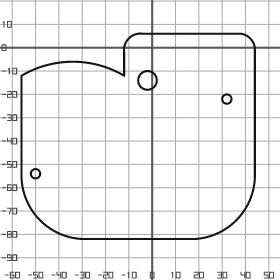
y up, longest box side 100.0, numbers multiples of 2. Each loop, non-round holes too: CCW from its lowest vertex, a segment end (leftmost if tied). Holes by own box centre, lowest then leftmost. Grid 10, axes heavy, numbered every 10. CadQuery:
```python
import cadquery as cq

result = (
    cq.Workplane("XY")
    .moveTo(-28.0, -82.0)
    .lineTo(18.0, -82.0)
    .threePointArc((36.0, -74.0), (44.0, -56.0))
    .lineTo(44.0, 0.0)
    .threePointArc((42.0, 4.0), (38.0, 6.0))
    .lineTo(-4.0, 6.0)
    .threePointArc((-10.0, 4.0), (-12.0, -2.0))
    .lineTo(-12.0, -12.0)
    .threePointArc((-34.0, -6.0), (-56.0, -12.0))
    .lineTo(-56.0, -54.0)
    .threePointArc((-48.0, -74.0), (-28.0, -82.0))
    .close()
    .moveTo(-50.0, -54.0)
    .circle(2.0)
    .moveTo(32.0, -22.0)
    .circle(2.0)
    .moveTo(-2.0, -14.0)
    .circle(4.0)
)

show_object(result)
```